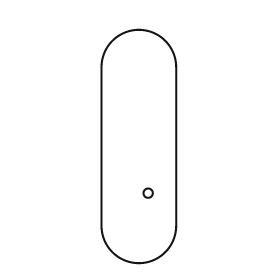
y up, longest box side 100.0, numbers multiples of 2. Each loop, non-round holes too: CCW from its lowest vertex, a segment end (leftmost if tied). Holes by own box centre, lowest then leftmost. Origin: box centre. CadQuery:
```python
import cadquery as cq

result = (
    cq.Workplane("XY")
    .moveTo(-16.0, -34.0)
    .threePointArc((0.0, -50.0), (16.0, -34.0))
    .lineTo(16.0, 34.0)
    .threePointArc((0.0, 50.0), (-16.0, 34.0))
    .close()
    .moveTo(4.0, -20.0)
    .circle(2.0)
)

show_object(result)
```